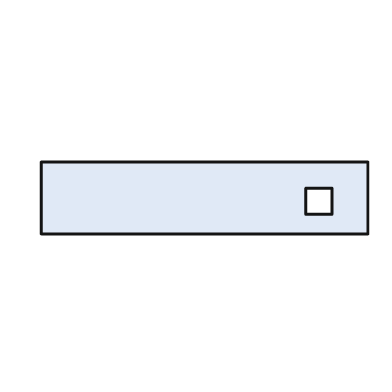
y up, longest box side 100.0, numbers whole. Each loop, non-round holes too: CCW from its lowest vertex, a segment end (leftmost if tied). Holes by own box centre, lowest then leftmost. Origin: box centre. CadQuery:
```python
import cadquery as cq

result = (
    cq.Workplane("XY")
    .moveTo(-50.0, -11.0)
    .lineTo(50.0, -11.0)
    .lineTo(50.0, 11.0)
    .lineTo(-50.0, 11.0)
    .close()
    .moveTo(31.0, -5.0)
    .lineTo(39.0, -5.0)
    .lineTo(39.0, 3.0)
    .lineTo(31.0, 3.0)
    .close()
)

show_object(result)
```